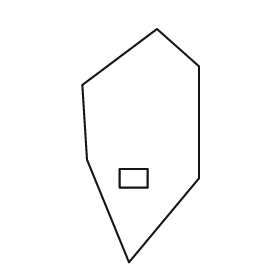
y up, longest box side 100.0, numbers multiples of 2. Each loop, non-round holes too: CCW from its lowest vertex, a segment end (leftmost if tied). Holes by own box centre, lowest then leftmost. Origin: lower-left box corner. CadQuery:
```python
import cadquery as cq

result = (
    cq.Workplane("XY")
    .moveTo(20.0, 0.0)
    .lineTo(50.0, 36.0)
    .lineTo(50.0, 84.0)
    .lineTo(32.0, 100.0)
    .lineTo(0.0, 76.0)
    .lineTo(2.0, 44.0)
    .close()
    .moveTo(16.0, 32.0)
    .lineTo(28.0, 32.0)
    .lineTo(28.0, 40.0)
    .lineTo(16.0, 40.0)
    .close()
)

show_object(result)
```